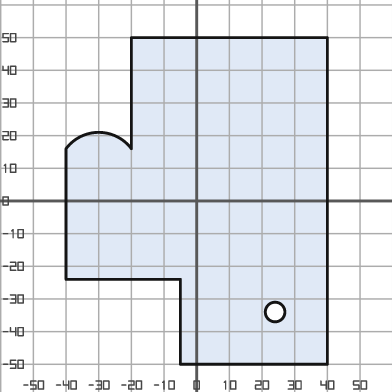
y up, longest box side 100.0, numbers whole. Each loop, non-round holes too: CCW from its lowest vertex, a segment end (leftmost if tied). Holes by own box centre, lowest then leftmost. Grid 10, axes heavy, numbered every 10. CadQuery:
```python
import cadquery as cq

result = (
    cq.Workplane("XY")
    .moveTo(-5.0, -50.0)
    .lineTo(40.0, -50.0)
    .lineTo(40.0, 50.0)
    .lineTo(-20.0, 50.0)
    .lineTo(-20.0, 16.0)
    .threePointArc((-30.0, 21.0), (-40.0, 16.0))
    .lineTo(-40.0, -24.0)
    .lineTo(-5.0, -24.0)
    .close()
    .moveTo(24.0, -34.0)
    .circle(3.0)
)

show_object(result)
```